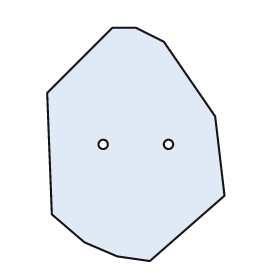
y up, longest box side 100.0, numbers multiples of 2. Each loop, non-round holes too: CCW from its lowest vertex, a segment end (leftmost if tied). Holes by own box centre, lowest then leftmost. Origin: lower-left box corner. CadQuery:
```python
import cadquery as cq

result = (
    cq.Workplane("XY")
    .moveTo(44.0, 0.0)
    .lineTo(76.0, 28.0)
    .lineTo(72.0, 62.0)
    .lineTo(50.0, 94.0)
    .lineTo(38.0, 100.0)
    .lineTo(28.0, 100.0)
    .lineTo(0.0, 72.0)
    .lineTo(2.0, 20.0)
    .lineTo(16.0, 8.0)
    .lineTo(30.0, 2.0)
    .close()
    .moveTo(24.0, 50.0)
    .circle(2.0)
    .moveTo(52.0, 50.0)
    .circle(2.0)
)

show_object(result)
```